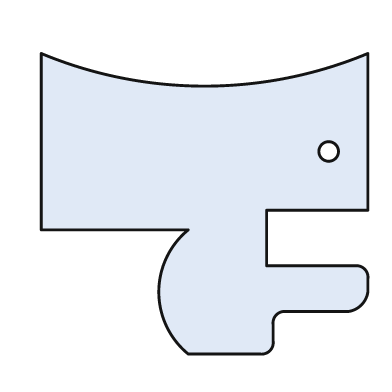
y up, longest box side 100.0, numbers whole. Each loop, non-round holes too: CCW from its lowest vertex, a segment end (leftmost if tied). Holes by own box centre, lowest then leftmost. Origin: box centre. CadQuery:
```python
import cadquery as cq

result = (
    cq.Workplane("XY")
    .moveTo(-5.0, -46.0)
    .lineTo(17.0, -46.0)
    .threePointArc((20.0, -45.0), (21.0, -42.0))
    .lineTo(21.0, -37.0)
    .threePointArc((22.0, -34.0), (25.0, -33.0))
    .lineTo(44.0, -33.0)
    .threePointArc((48.0, -31.0), (50.0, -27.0))
    .lineTo(50.0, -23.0)
    .threePointArc((49.0, -20.0), (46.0, -19.0))
    .lineTo(19.0, -19.0)
    .lineTo(19.0, -2.0)
    .lineTo(50.0, -2.0)
    .lineTo(50.0, 46.0)
    .threePointArc((0.0, 36.0), (-50.0, 46.0))
    .lineTo(-50.0, -8.0)
    .lineTo(-5.0, -8.0)
    .threePointArc((-14.0, -27.0), (-5.0, -46.0))
    .close()
    .moveTo(38.0, 16.0)
    .circle(3.0)
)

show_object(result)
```